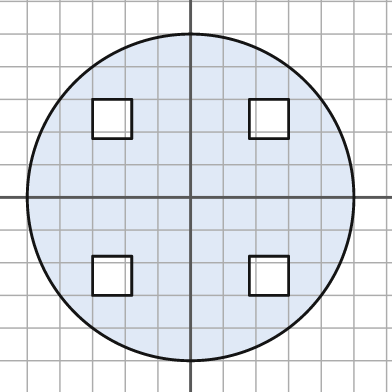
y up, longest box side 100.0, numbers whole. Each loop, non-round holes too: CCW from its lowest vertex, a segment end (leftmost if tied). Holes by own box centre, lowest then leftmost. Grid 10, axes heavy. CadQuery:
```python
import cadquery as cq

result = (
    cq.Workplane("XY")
    .moveTo(0.0, 0.0)
    .circle(50.0)
    .moveTo(-30.0, -30.0)
    .lineTo(-18.0, -30.0)
    .lineTo(-18.0, -18.0)
    .lineTo(-30.0, -18.0)
    .close()
    .moveTo(18.0, -30.0)
    .lineTo(30.0, -30.0)
    .lineTo(30.0, -18.0)
    .lineTo(18.0, -18.0)
    .close()
    .moveTo(-30.0, 18.0)
    .lineTo(-18.0, 18.0)
    .lineTo(-18.0, 30.0)
    .lineTo(-30.0, 30.0)
    .close()
    .moveTo(18.0, 18.0)
    .lineTo(30.0, 18.0)
    .lineTo(30.0, 30.0)
    .lineTo(18.0, 30.0)
    .close()
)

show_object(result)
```